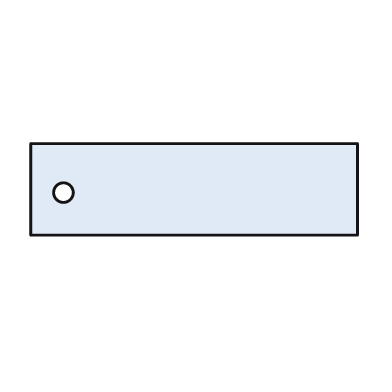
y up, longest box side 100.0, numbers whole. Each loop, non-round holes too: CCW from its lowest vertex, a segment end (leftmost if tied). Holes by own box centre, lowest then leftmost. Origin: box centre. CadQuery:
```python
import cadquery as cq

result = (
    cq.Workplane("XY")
    .moveTo(-50.0, -14.0)
    .lineTo(50.0, -14.0)
    .lineTo(50.0, 14.0)
    .lineTo(-50.0, 14.0)
    .close()
    .moveTo(-40.0, -1.0)
    .circle(3.0)
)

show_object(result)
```